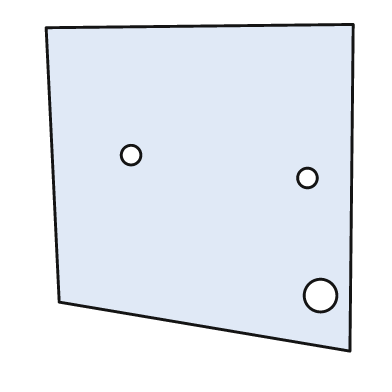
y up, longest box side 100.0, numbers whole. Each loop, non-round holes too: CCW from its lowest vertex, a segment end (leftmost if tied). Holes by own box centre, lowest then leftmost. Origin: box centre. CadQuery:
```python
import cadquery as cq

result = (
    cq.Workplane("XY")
    .moveTo(46.0, -50.0)
    .lineTo(47.0, 50.0)
    .lineTo(-47.0, 49.0)
    .lineTo(-43.0, -35.0)
    .close()
    .moveTo(37.0, -33.0)
    .circle(5.0)
    .moveTo(33.0, 3.0)
    .circle(3.0)
    .moveTo(-21.0, 10.0)
    .circle(3.0)
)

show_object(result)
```